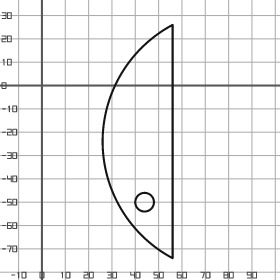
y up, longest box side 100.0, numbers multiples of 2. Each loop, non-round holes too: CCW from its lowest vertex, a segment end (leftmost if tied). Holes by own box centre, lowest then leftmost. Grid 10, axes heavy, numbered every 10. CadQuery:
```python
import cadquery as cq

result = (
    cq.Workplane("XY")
    .moveTo(56.0, -74.0)
    .lineTo(56.0, 26.0)
    .threePointArc((26.0, -24.0), (56.0, -74.0))
    .close()
    .moveTo(44.0, -50.0)
    .circle(4.0)
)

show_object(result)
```